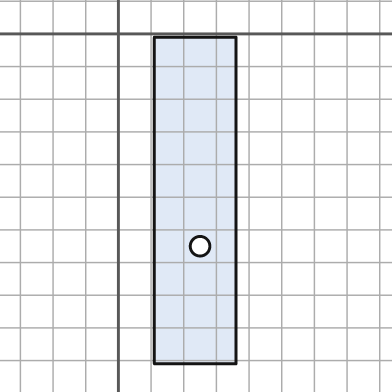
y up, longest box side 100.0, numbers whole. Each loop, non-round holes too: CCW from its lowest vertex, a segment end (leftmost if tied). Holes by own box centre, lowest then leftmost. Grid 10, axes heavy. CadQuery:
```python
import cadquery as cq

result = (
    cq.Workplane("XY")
    .moveTo(11.0, -101.0)
    .lineTo(36.0, -101.0)
    .lineTo(36.0, -1.0)
    .lineTo(11.0, -1.0)
    .close()
    .moveTo(25.0, -65.0)
    .circle(3.0)
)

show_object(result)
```